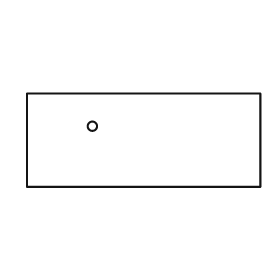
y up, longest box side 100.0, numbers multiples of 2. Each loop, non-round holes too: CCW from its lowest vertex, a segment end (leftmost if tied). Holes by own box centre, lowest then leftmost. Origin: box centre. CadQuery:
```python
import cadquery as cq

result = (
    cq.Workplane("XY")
    .moveTo(-50.0, -20.0)
    .lineTo(50.0, -20.0)
    .lineTo(50.0, 20.0)
    .lineTo(-50.0, 20.0)
    .close()
    .moveTo(-22.0, 6.0)
    .circle(2.0)
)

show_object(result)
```